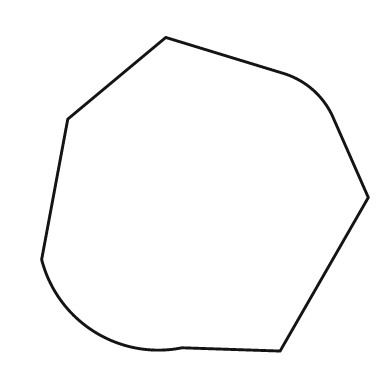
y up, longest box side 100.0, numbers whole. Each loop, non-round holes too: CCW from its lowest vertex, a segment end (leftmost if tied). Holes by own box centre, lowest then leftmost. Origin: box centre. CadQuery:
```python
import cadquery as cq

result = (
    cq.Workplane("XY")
    .moveTo(23.0, -48.0)
    .lineTo(50.0, -1.0)
    .lineTo(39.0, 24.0)
    .threePointArc((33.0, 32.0), (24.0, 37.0))
    .lineTo(-12.0, 48.0)
    .lineTo(-42.0, 23.0)
    .lineTo(-50.0, -20.0)
    .threePointArc((-34.0, -42.0), (-7.0, -47.0))
    .close()
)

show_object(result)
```